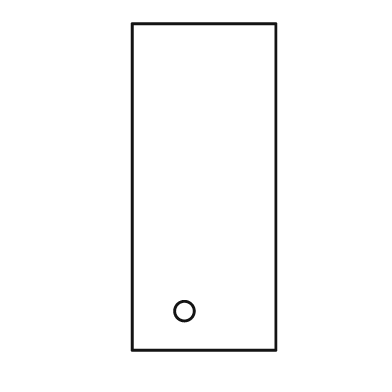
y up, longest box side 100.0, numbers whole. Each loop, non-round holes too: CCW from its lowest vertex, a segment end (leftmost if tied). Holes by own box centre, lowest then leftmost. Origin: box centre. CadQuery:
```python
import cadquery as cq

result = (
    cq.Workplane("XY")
    .moveTo(-22.0, -50.0)
    .lineTo(22.0, -50.0)
    .lineTo(22.0, 50.0)
    .lineTo(-22.0, 50.0)
    .close()
    .moveTo(-6.0, -38.0)
    .circle(3.0)
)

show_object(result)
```